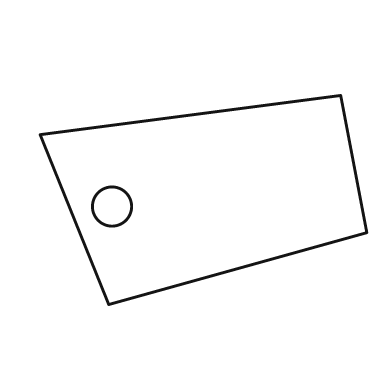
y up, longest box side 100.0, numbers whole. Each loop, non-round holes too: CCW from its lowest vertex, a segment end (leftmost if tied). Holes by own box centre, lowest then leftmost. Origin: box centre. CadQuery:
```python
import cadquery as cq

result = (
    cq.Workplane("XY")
    .moveTo(-29.0, -32.0)
    .lineTo(50.0, -10.0)
    .lineTo(42.0, 32.0)
    .lineTo(-50.0, 20.0)
    .close()
    .moveTo(-28.0, -2.0)
    .circle(6.0)
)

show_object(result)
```